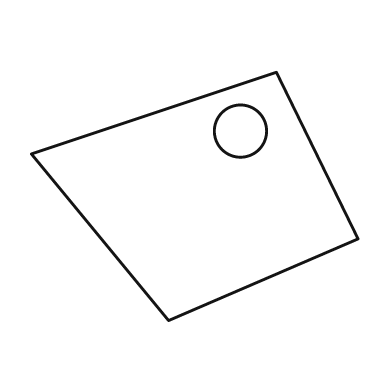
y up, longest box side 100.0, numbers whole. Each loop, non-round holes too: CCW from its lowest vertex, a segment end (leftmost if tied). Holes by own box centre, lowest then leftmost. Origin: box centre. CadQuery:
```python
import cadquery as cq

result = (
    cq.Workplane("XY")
    .moveTo(-8.0, -38.0)
    .lineTo(50.0, -13.0)
    .lineTo(25.0, 38.0)
    .lineTo(-50.0, 13.0)
    .close()
    .moveTo(14.0, 20.0)
    .circle(8.0)
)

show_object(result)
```